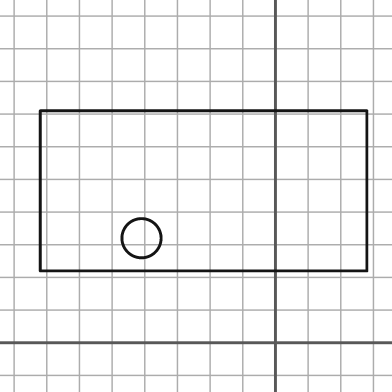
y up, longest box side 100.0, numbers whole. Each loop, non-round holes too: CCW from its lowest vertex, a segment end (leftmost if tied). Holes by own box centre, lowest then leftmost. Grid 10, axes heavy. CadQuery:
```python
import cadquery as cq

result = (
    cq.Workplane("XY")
    .moveTo(-72.0, 22.0)
    .lineTo(28.0, 22.0)
    .lineTo(28.0, 71.0)
    .lineTo(-72.0, 71.0)
    .close()
    .moveTo(-41.0, 32.0)
    .circle(6.0)
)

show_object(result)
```